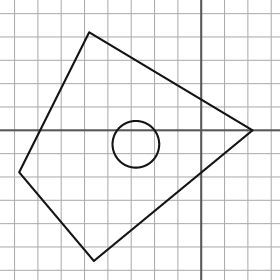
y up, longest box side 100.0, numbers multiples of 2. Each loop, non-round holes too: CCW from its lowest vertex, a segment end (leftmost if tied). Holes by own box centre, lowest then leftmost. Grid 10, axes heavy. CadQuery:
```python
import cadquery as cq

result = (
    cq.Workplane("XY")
    .moveTo(-46.0, -56.0)
    .lineTo(22.0, 0.0)
    .lineTo(-48.0, 42.0)
    .lineTo(-78.0, -18.0)
    .close()
    .moveTo(-28.0, -6.0)
    .circle(10.0)
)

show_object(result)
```